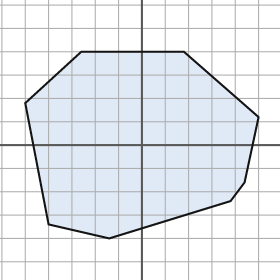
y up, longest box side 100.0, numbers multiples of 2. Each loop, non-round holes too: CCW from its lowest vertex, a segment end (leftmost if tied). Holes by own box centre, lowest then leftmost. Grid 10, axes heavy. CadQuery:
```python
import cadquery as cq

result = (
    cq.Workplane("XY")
    .moveTo(-14.0, -40.0)
    .lineTo(38.0, -24.0)
    .lineTo(44.0, -16.0)
    .lineTo(50.0, 12.0)
    .lineTo(18.0, 40.0)
    .lineTo(-26.0, 40.0)
    .lineTo(-50.0, 18.0)
    .lineTo(-40.0, -34.0)
    .close()
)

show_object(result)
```